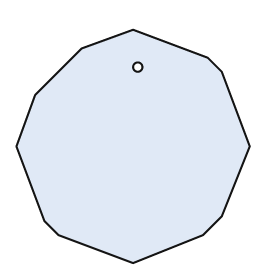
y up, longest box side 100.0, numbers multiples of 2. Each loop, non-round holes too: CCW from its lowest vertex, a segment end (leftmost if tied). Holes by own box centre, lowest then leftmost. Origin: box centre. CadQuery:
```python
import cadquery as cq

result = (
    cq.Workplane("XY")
    .moveTo(0.0, -50.0)
    .lineTo(30.0, -38.0)
    .lineTo(38.0, -30.0)
    .lineTo(50.0, 0.0)
    .lineTo(38.0, 32.0)
    .lineTo(32.0, 38.0)
    .lineTo(0.0, 50.0)
    .lineTo(-22.0, 42.0)
    .lineTo(-42.0, 22.0)
    .lineTo(-50.0, 0.0)
    .lineTo(-38.0, -32.0)
    .lineTo(-32.0, -38.0)
    .close()
    .moveTo(2.0, 34.0)
    .circle(2.0)
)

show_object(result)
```